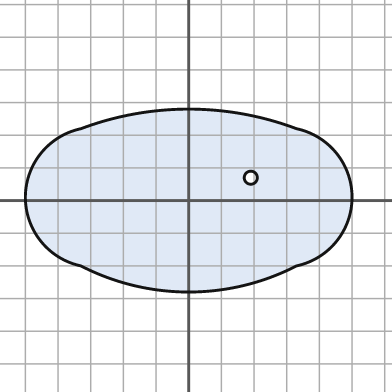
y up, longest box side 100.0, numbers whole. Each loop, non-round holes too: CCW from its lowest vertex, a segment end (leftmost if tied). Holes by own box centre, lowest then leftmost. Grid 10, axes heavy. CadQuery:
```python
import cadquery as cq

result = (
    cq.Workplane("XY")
    .moveTo(-33.0, -20.0)
    .threePointArc((0.0, -28.0), (33.0, -20.0))
    .threePointArc((50.0, 1.0), (33.0, 22.0))
    .threePointArc((0.0, 28.0), (-33.0, 22.0))
    .threePointArc((-50.0, 1.0), (-33.0, -20.0))
    .close()
    .moveTo(19.0, 7.0)
    .circle(2.0)
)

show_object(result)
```